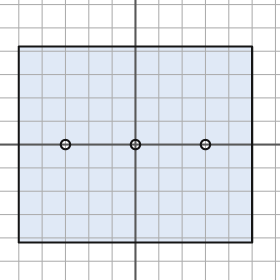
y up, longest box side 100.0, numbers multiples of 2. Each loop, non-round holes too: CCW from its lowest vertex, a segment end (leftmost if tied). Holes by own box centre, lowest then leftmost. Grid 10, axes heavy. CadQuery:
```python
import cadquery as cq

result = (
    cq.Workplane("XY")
    .moveTo(-50.0, -42.0)
    .lineTo(50.0, -42.0)
    .lineTo(50.0, 42.0)
    .lineTo(-50.0, 42.0)
    .close()
    .moveTo(-30.0, 0.0)
    .circle(2.0)
    .moveTo(0.0, 0.0)
    .circle(2.0)
    .moveTo(30.0, 0.0)
    .circle(2.0)
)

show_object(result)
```